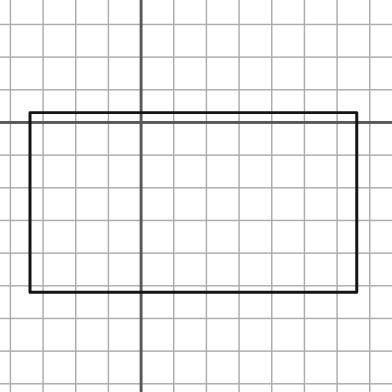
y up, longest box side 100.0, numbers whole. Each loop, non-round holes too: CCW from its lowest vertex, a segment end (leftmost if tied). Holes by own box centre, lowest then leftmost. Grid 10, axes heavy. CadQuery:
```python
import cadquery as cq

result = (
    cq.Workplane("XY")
    .moveTo(-34.0, -52.0)
    .lineTo(66.0, -52.0)
    .lineTo(66.0, 3.0)
    .lineTo(-34.0, 3.0)
    .close()
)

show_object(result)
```